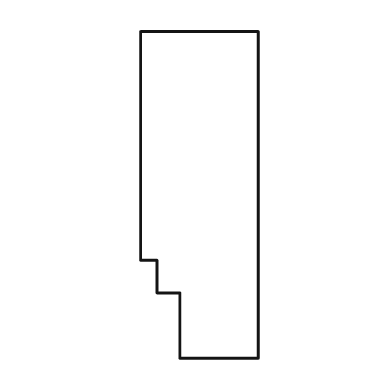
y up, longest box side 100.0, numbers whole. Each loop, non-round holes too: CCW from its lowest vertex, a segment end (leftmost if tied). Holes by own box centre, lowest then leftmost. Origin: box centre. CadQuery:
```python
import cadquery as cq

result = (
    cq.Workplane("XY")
    .moveTo(-6.0, -50.0)
    .lineTo(18.0, -50.0)
    .lineTo(18.0, 50.0)
    .lineTo(-18.0, 50.0)
    .lineTo(-18.0, -20.0)
    .lineTo(-13.0, -20.0)
    .lineTo(-13.0, -30.0)
    .lineTo(-6.0, -30.0)
    .close()
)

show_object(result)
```